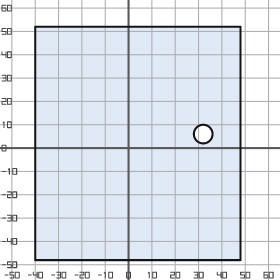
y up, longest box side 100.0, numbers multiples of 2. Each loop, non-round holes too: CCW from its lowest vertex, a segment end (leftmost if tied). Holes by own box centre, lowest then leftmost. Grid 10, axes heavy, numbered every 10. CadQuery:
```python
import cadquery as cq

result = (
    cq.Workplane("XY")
    .moveTo(-40.0, -48.0)
    .lineTo(48.0, -48.0)
    .lineTo(48.0, 52.0)
    .lineTo(-40.0, 52.0)
    .close()
    .moveTo(32.0, 6.0)
    .circle(4.0)
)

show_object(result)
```